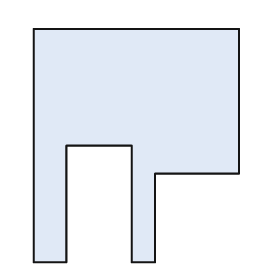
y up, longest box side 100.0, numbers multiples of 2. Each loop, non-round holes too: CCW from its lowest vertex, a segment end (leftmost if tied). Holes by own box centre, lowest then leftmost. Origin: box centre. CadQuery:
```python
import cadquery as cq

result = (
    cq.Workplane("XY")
    .moveTo(-44.0, -50.0)
    .lineTo(-30.0, -50.0)
    .lineTo(-30.0, 0.0)
    .lineTo(-2.0, 0.0)
    .lineTo(-2.0, -50.0)
    .lineTo(8.0, -50.0)
    .lineTo(8.0, -12.0)
    .lineTo(44.0, -12.0)
    .lineTo(44.0, 50.0)
    .lineTo(-44.0, 50.0)
    .close()
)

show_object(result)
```